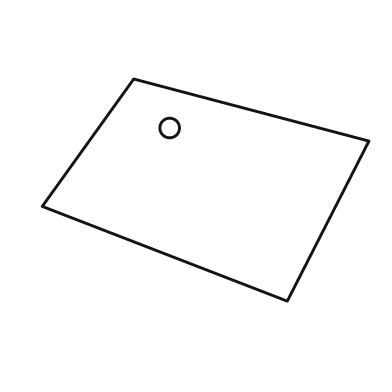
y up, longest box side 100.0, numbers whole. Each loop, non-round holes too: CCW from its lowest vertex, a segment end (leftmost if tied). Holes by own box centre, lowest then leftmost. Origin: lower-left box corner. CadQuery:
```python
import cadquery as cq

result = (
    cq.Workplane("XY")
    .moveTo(75.0, 0.0)
    .lineTo(100.0, 49.0)
    .lineTo(28.0, 68.0)
    .lineTo(0.0, 29.0)
    .close()
    .moveTo(39.0, 53.0)
    .circle(3.0)
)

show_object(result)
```